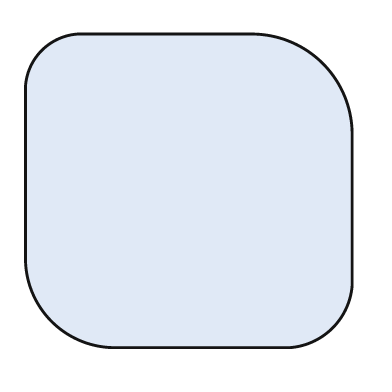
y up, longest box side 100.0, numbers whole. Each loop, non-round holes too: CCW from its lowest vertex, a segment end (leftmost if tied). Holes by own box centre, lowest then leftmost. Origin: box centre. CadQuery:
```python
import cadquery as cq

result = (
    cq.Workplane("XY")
    .moveTo(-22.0, -48.0)
    .lineTo(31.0, -48.0)
    .threePointArc((44.0, -42.0), (50.0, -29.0))
    .lineTo(50.0, 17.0)
    .threePointArc((41.0, 39.0), (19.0, 48.0))
    .lineTo(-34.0, 48.0)
    .threePointArc((-45.0, 43.0), (-50.0, 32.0))
    .lineTo(-50.0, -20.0)
    .threePointArc((-42.0, -40.0), (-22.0, -48.0))
    .close()
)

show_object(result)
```